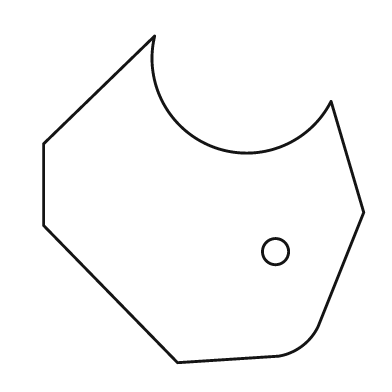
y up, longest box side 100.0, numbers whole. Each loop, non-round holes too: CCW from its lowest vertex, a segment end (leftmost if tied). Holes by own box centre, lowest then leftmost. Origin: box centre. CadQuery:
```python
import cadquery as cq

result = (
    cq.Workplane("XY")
    .moveTo(-8.0, -50.0)
    .lineTo(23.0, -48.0)
    .threePointArc((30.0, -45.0), (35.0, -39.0))
    .lineTo(49.0, -4.0)
    .lineTo(39.0, 30.0)
    .threePointArc((3.0, 16.0), (-15.0, 50.0))
    .lineTo(-49.0, 17.0)
    .lineTo(-49.0, -8.0)
    .close()
    .moveTo(22.0, -16.0)
    .circle(4.0)
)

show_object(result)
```